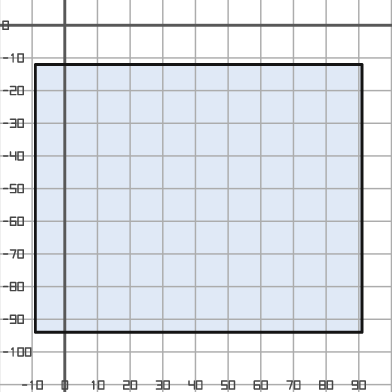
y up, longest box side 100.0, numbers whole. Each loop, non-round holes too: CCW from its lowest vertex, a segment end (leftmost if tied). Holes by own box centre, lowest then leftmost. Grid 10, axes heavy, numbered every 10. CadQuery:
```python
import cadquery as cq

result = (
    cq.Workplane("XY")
    .moveTo(-9.0, -94.0)
    .lineTo(91.0, -94.0)
    .lineTo(91.0, -12.0)
    .lineTo(-9.0, -12.0)
    .close()
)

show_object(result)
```